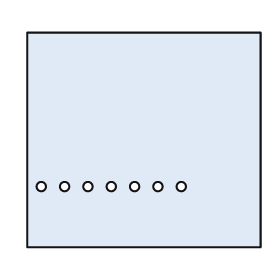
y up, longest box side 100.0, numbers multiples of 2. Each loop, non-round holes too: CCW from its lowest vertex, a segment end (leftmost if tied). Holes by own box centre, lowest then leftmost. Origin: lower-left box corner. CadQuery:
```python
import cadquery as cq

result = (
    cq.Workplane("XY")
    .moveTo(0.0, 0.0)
    .lineTo(100.0, 0.0)
    .lineTo(100.0, 92.0)
    .lineTo(0.0, 92.0)
    .close()
    .moveTo(6.0, 26.0)
    .circle(2.0)
    .moveTo(16.0, 26.0)
    .circle(2.0)
    .moveTo(26.0, 26.0)
    .circle(2.0)
    .moveTo(36.0, 26.0)
    .circle(2.0)
    .moveTo(46.0, 26.0)
    .circle(2.0)
    .moveTo(56.0, 26.0)
    .circle(2.0)
    .moveTo(66.0, 26.0)
    .circle(2.0)
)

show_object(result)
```